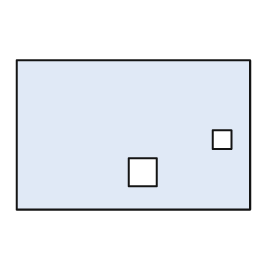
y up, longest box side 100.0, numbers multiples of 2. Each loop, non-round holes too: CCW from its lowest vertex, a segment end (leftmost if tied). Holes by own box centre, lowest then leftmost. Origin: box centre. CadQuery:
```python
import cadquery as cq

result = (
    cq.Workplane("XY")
    .moveTo(-50.0, -32.0)
    .lineTo(50.0, -32.0)
    .lineTo(50.0, 32.0)
    .lineTo(-50.0, 32.0)
    .close()
    .moveTo(-2.0, -22.0)
    .lineTo(10.0, -22.0)
    .lineTo(10.0, -10.0)
    .lineTo(-2.0, -10.0)
    .close()
    .moveTo(34.0, -6.0)
    .lineTo(42.0, -6.0)
    .lineTo(42.0, 2.0)
    .lineTo(34.0, 2.0)
    .close()
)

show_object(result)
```